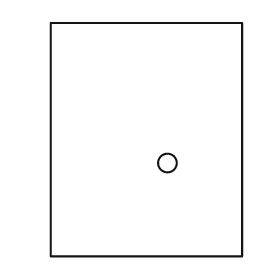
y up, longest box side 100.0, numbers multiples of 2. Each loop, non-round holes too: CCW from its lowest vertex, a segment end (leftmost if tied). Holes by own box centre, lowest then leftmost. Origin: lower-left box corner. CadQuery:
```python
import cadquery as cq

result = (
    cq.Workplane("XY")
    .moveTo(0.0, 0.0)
    .lineTo(82.0, 0.0)
    .lineTo(82.0, 100.0)
    .lineTo(0.0, 100.0)
    .close()
    .moveTo(50.0, 40.0)
    .circle(4.0)
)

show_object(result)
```